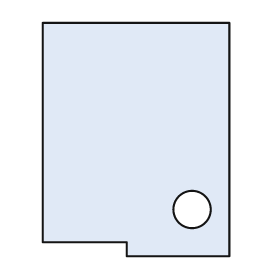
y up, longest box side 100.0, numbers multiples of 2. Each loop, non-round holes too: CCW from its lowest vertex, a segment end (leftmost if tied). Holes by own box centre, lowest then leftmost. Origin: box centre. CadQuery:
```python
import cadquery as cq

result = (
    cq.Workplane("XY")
    .moveTo(-4.0, -50.0)
    .lineTo(40.0, -50.0)
    .lineTo(40.0, 50.0)
    .lineTo(-40.0, 50.0)
    .lineTo(-40.0, -44.0)
    .lineTo(-4.0, -44.0)
    .close()
    .moveTo(24.0, -30.0)
    .circle(8.0)
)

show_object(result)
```